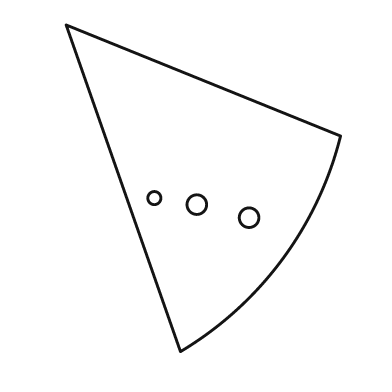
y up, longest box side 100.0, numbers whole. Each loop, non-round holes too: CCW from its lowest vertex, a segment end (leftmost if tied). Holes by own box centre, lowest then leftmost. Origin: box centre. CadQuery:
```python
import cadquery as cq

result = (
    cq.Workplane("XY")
    .moveTo(-7.0, -50.0)
    .threePointArc((24.0, -22.0), (42.0, 16.0))
    .lineTo(-42.0, 50.0)
    .close()
    .moveTo(14.0, -9.0)
    .circle(3.0)
    .moveTo(-2.0, -5.0)
    .circle(3.0)
    .moveTo(-15.0, -3.0)
    .circle(2.0)
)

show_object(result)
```